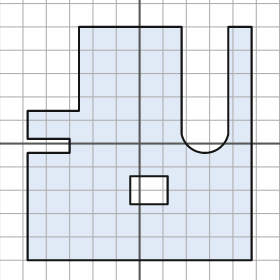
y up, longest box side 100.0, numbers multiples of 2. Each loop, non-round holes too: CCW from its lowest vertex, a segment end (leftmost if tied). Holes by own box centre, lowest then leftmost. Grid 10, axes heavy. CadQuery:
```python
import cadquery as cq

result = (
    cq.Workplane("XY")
    .moveTo(-48.0, -50.0)
    .lineTo(48.0, -50.0)
    .lineTo(48.0, 50.0)
    .lineTo(38.0, 50.0)
    .lineTo(38.0, 4.0)
    .threePointArc((28.0, -4.0), (18.0, 4.0))
    .lineTo(18.0, 50.0)
    .lineTo(-26.0, 50.0)
    .lineTo(-26.0, 14.0)
    .lineTo(-48.0, 14.0)
    .lineTo(-48.0, 2.0)
    .lineTo(-30.0, 2.0)
    .lineTo(-30.0, -4.0)
    .lineTo(-48.0, -4.0)
    .close()
    .moveTo(-4.0, -26.0)
    .lineTo(12.0, -26.0)
    .lineTo(12.0, -14.0)
    .lineTo(-4.0, -14.0)
    .close()
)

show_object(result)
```